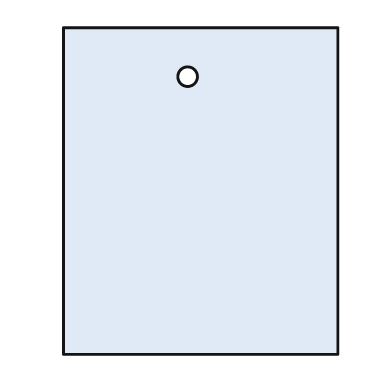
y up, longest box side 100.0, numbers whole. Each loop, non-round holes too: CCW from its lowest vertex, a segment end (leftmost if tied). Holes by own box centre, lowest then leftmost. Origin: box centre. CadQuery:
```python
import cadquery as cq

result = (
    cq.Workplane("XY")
    .moveTo(-42.0, -50.0)
    .lineTo(42.0, -50.0)
    .lineTo(42.0, 50.0)
    .lineTo(-42.0, 50.0)
    .close()
    .moveTo(-4.0, 35.0)
    .circle(3.0)
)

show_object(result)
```